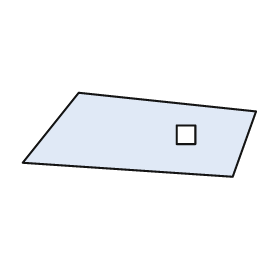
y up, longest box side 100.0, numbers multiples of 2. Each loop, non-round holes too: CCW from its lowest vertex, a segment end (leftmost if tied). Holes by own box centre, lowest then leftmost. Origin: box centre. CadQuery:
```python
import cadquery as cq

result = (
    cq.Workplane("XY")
    .moveTo(40.0, -18.0)
    .lineTo(50.0, 10.0)
    .lineTo(-26.0, 18.0)
    .lineTo(-50.0, -12.0)
    .close()
    .moveTo(16.0, -4.0)
    .lineTo(24.0, -4.0)
    .lineTo(24.0, 4.0)
    .lineTo(16.0, 4.0)
    .close()
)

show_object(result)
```